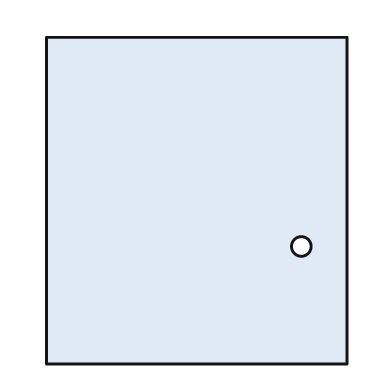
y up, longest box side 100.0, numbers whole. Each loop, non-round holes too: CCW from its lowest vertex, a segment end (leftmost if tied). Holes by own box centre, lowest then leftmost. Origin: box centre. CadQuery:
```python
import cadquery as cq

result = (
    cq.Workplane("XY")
    .moveTo(-46.0, -50.0)
    .lineTo(46.0, -50.0)
    .lineTo(46.0, 50.0)
    .lineTo(-46.0, 50.0)
    .close()
    .moveTo(32.0, -14.0)
    .circle(3.0)
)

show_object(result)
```